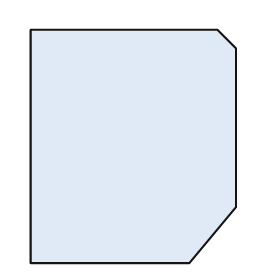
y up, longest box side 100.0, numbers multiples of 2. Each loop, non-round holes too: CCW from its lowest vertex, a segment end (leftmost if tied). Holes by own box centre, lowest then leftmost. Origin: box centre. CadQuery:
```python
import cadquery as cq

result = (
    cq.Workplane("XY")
    .moveTo(-44.0, -50.0)
    .lineTo(24.0, -50.0)
    .lineTo(44.0, -26.0)
    .lineTo(44.0, 42.0)
    .lineTo(36.0, 50.0)
    .lineTo(-44.0, 50.0)
    .close()
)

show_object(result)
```